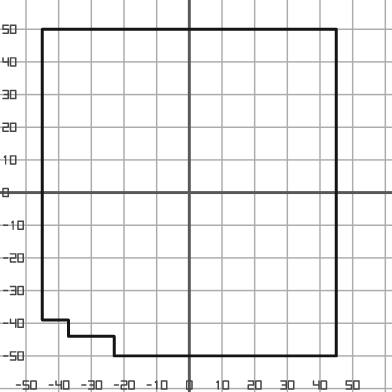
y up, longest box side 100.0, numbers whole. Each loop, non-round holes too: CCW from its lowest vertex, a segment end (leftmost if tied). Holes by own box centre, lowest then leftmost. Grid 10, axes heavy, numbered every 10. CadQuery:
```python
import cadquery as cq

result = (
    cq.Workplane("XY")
    .moveTo(-23.0, -50.0)
    .lineTo(45.0, -50.0)
    .lineTo(45.0, 50.0)
    .lineTo(-45.0, 50.0)
    .lineTo(-45.0, -39.0)
    .lineTo(-37.0, -39.0)
    .lineTo(-37.0, -44.0)
    .lineTo(-23.0, -44.0)
    .close()
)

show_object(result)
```